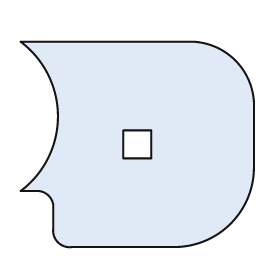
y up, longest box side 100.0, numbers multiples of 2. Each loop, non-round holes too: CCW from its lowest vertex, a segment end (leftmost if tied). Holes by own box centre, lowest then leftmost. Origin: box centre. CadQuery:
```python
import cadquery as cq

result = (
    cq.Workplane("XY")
    .moveTo(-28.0, -44.0)
    .lineTo(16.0, -44.0)
    .threePointArc((40.0, -34.0), (50.0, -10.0))
    .lineTo(50.0, 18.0)
    .threePointArc((42.0, 36.0), (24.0, 44.0))
    .lineTo(-50.0, 44.0)
    .threePointArc((-34.0, 12.0), (-50.0, -20.0))
    .lineTo(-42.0, -20.0)
    .threePointArc((-38.0, -22.0), (-36.0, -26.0))
    .lineTo(-36.0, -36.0)
    .threePointArc((-34.0, -42.0), (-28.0, -44.0))
    .close()
    .moveTo(-6.0, -6.0)
    .lineTo(6.0, -6.0)
    .lineTo(6.0, 6.0)
    .lineTo(-6.0, 6.0)
    .close()
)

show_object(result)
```